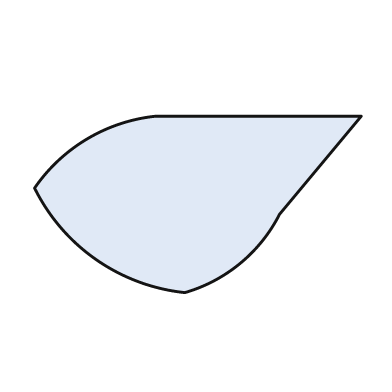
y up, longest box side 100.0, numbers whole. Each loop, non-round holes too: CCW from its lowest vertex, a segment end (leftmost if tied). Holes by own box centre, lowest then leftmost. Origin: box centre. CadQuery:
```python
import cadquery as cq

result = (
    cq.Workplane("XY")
    .moveTo(-4.0, -27.0)
    .threePointArc((13.0, -18.0), (25.0, -3.0))
    .lineTo(50.0, 27.0)
    .lineTo(-13.0, 27.0)
    .threePointArc((-34.0, 20.0), (-50.0, 5.0))
    .threePointArc((-31.0, -17.0), (-4.0, -27.0))
    .close()
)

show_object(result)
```